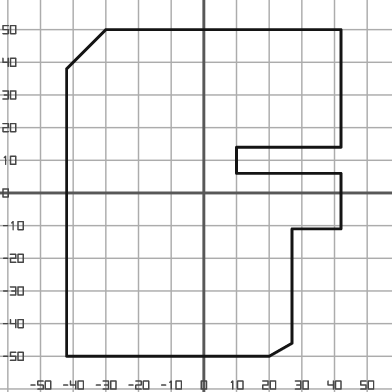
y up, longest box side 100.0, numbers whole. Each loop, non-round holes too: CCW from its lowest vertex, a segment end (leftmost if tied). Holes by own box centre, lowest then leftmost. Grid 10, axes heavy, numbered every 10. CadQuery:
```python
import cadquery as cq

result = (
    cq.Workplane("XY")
    .moveTo(-42.0, -50.0)
    .lineTo(20.0, -50.0)
    .lineTo(27.0, -46.0)
    .lineTo(27.0, -11.0)
    .lineTo(42.0, -11.0)
    .lineTo(42.0, 6.0)
    .lineTo(10.0, 6.0)
    .lineTo(10.0, 14.0)
    .lineTo(42.0, 14.0)
    .lineTo(42.0, 50.0)
    .lineTo(-30.0, 50.0)
    .lineTo(-42.0, 38.0)
    .close()
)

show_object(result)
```